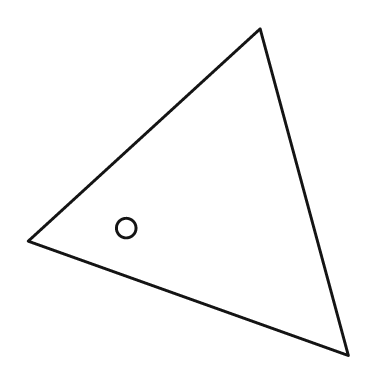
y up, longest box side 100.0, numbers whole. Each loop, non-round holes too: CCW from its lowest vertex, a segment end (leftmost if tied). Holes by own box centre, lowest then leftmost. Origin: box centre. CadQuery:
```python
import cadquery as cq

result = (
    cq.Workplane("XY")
    .moveTo(49.0, -50.0)
    .lineTo(22.0, 50.0)
    .lineTo(-49.0, -15.0)
    .close()
    .moveTo(-19.0, -11.0)
    .circle(3.0)
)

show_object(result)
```